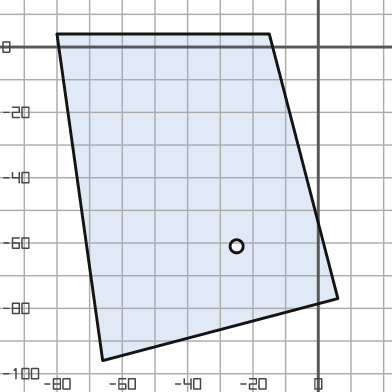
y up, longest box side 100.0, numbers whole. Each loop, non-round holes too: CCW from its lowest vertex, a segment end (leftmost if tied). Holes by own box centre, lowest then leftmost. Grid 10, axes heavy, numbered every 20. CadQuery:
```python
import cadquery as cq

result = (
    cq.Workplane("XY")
    .moveTo(-66.0, -96.0)
    .lineTo(6.0, -77.0)
    .lineTo(-15.0, 4.0)
    .lineTo(-80.0, 4.0)
    .close()
    .moveTo(-25.0, -61.0)
    .circle(2.0)
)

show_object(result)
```